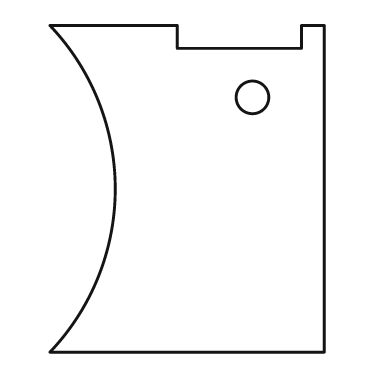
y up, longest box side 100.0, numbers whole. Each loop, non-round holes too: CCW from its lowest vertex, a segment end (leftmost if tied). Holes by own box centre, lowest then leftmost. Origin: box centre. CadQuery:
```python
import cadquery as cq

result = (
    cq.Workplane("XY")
    .moveTo(-42.0, -50.0)
    .lineTo(42.0, -50.0)
    .lineTo(42.0, 50.0)
    .lineTo(35.0, 50.0)
    .lineTo(35.0, 43.0)
    .lineTo(-3.0, 43.0)
    .lineTo(-3.0, 50.0)
    .lineTo(-42.0, 50.0)
    .threePointArc((-22.0, 0.0), (-42.0, -50.0))
    .close()
    .moveTo(20.0, 28.0)
    .circle(5.0)
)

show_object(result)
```